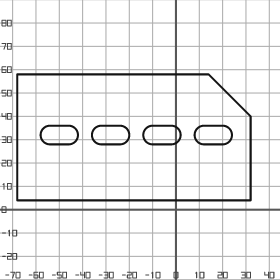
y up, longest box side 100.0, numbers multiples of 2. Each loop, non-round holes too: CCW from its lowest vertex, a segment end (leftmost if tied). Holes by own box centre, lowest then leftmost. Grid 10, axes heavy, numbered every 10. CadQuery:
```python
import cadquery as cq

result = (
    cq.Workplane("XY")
    .moveTo(-68.0, 4.0)
    .lineTo(32.0, 4.0)
    .lineTo(32.0, 40.0)
    .lineTo(14.0, 58.0)
    .lineTo(-68.0, 58.0)
    .close()
    .moveTo(-54.0, 28.0)
    .lineTo(-46.0, 28.0)
    .threePointArc((-42.0, 32.0), (-46.0, 36.0))
    .lineTo(-54.0, 36.0)
    .threePointArc((-58.0, 32.0), (-54.0, 28.0))
    .close()
    .moveTo(-32.0, 28.0)
    .lineTo(-24.0, 28.0)
    .threePointArc((-20.0, 32.0), (-24.0, 36.0))
    .lineTo(-32.0, 36.0)
    .threePointArc((-36.0, 32.0), (-32.0, 28.0))
    .close()
    .moveTo(-10.0, 28.0)
    .lineTo(-2.0, 28.0)
    .threePointArc((2.0, 32.0), (-2.0, 36.0))
    .lineTo(-10.0, 36.0)
    .threePointArc((-14.0, 32.0), (-10.0, 28.0))
    .close()
    .moveTo(12.0, 28.0)
    .lineTo(20.0, 28.0)
    .threePointArc((24.0, 32.0), (20.0, 36.0))
    .lineTo(12.0, 36.0)
    .threePointArc((8.0, 32.0), (12.0, 28.0))
    .close()
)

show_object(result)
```